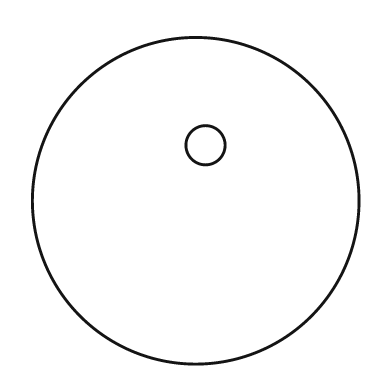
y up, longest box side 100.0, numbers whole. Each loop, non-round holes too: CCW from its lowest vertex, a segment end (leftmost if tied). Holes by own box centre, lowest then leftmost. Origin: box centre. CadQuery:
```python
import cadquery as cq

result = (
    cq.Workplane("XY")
    .moveTo(0.0, 0.0)
    .circle(50.0)
    .moveTo(3.0, 17.0)
    .circle(6.0)
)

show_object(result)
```